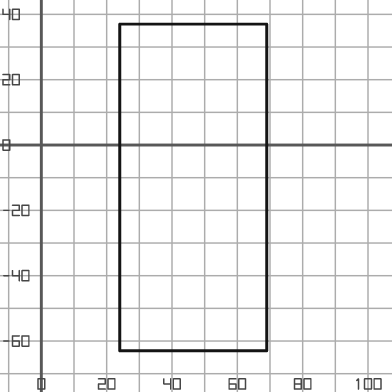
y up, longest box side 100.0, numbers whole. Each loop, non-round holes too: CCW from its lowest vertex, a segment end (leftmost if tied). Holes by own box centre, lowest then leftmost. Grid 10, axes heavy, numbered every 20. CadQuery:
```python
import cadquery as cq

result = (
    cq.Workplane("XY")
    .moveTo(24.0, -63.0)
    .lineTo(69.0, -63.0)
    .lineTo(69.0, 37.0)
    .lineTo(24.0, 37.0)
    .close()
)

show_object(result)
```